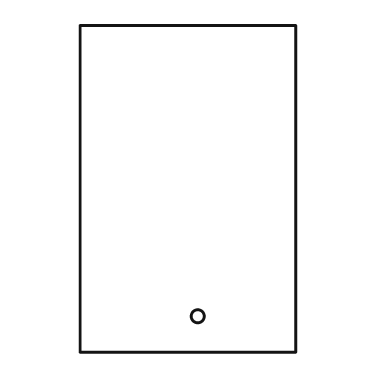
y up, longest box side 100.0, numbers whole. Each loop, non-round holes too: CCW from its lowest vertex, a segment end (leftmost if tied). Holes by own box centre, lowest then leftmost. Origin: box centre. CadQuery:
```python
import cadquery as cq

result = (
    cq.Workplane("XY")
    .moveTo(-33.0, -50.0)
    .lineTo(33.0, -50.0)
    .lineTo(33.0, 50.0)
    .lineTo(-33.0, 50.0)
    .close()
    .moveTo(3.0, -39.0)
    .circle(2.0)
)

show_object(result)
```